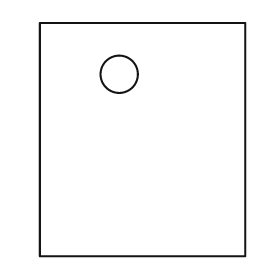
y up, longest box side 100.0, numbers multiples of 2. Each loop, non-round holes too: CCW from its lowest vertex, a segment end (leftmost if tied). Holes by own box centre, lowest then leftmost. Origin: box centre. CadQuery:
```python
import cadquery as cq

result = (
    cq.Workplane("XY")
    .moveTo(-44.0, -50.0)
    .lineTo(44.0, -50.0)
    .lineTo(44.0, 50.0)
    .lineTo(-44.0, 50.0)
    .close()
    .moveTo(-10.0, 28.0)
    .circle(8.0)
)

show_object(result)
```